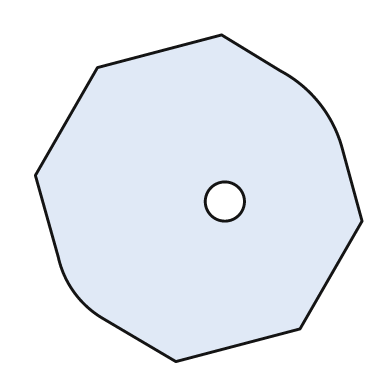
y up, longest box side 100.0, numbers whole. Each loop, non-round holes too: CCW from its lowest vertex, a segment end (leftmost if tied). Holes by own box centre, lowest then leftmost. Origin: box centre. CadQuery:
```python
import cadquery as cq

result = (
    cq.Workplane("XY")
    .moveTo(-7.0, -50.0)
    .lineTo(31.0, -40.0)
    .lineTo(50.0, -7.0)
    .lineTo(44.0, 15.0)
    .threePointArc((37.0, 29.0), (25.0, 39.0))
    .lineTo(7.0, 50.0)
    .lineTo(-31.0, 40.0)
    .lineTo(-50.0, 7.0)
    .lineTo(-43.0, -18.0)
    .threePointArc((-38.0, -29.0), (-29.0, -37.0))
    .close()
    .moveTo(8.0, -1.0)
    .circle(6.0)
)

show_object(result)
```